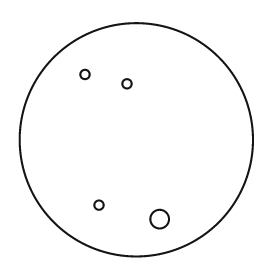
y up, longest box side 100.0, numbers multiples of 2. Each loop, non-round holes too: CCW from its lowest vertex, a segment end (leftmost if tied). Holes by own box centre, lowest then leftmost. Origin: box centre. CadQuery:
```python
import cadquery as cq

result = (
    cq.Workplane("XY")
    .moveTo(0.0, 0.0)
    .circle(50.0)
    .moveTo(10.0, -34.0)
    .circle(4.0)
    .moveTo(-16.0, -28.0)
    .circle(2.0)
    .moveTo(-4.0, 24.0)
    .circle(2.0)
    .moveTo(-22.0, 28.0)
    .circle(2.0)
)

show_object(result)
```